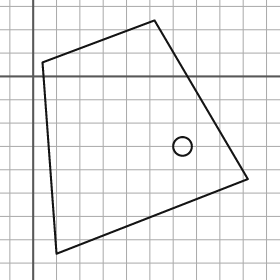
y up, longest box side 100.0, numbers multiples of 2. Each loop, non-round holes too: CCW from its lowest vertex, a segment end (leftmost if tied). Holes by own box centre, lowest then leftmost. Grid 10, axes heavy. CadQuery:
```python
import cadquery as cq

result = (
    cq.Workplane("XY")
    .moveTo(10.0, -76.0)
    .lineTo(92.0, -44.0)
    .lineTo(52.0, 24.0)
    .lineTo(4.0, 6.0)
    .close()
    .moveTo(64.0, -30.0)
    .circle(4.0)
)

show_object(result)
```